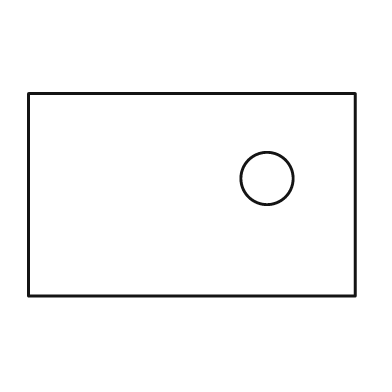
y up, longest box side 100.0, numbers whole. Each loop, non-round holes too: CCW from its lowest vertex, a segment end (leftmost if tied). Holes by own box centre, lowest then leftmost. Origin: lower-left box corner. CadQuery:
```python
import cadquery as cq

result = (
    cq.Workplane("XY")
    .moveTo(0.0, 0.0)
    .lineTo(100.0, 0.0)
    .lineTo(100.0, 62.0)
    .lineTo(0.0, 62.0)
    .close()
    .moveTo(73.0, 36.0)
    .circle(8.0)
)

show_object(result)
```